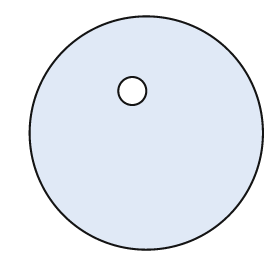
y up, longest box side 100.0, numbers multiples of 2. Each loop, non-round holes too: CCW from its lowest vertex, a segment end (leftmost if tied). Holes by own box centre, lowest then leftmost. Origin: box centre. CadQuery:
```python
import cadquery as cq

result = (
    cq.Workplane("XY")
    .moveTo(0.0, 0.0)
    .circle(50.0)
    .moveTo(-6.0, 18.0)
    .circle(6.0)
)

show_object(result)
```